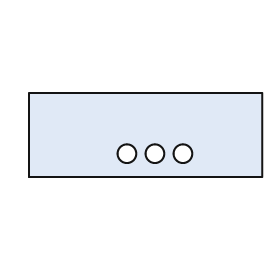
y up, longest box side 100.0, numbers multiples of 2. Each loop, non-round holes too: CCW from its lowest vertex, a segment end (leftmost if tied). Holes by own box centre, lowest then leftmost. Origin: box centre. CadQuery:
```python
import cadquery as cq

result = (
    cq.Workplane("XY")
    .moveTo(-50.0, -18.0)
    .lineTo(50.0, -18.0)
    .lineTo(50.0, 18.0)
    .lineTo(-50.0, 18.0)
    .close()
    .moveTo(-8.0, -8.0)
    .circle(4.0)
    .moveTo(4.0, -8.0)
    .circle(4.0)
    .moveTo(16.0, -8.0)
    .circle(4.0)
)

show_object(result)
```